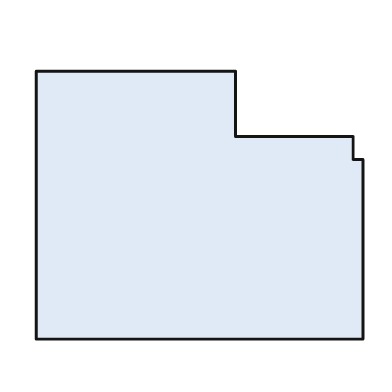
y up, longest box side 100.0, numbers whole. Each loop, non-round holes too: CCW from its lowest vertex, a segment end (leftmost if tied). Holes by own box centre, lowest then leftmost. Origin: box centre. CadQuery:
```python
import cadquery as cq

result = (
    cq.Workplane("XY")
    .moveTo(-50.0, -41.0)
    .lineTo(50.0, -41.0)
    .lineTo(50.0, 14.0)
    .lineTo(47.0, 14.0)
    .lineTo(47.0, 21.0)
    .lineTo(11.0, 21.0)
    .lineTo(11.0, 41.0)
    .lineTo(-50.0, 41.0)
    .close()
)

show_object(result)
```